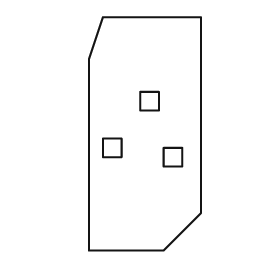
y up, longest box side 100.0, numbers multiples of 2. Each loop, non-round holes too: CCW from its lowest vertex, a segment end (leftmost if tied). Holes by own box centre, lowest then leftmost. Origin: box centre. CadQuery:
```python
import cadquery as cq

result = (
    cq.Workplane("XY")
    .moveTo(-24.0, -50.0)
    .lineTo(8.0, -50.0)
    .lineTo(24.0, -34.0)
    .lineTo(24.0, 50.0)
    .lineTo(-18.0, 50.0)
    .lineTo(-24.0, 32.0)
    .close()
    .moveTo(8.0, -14.0)
    .lineTo(16.0, -14.0)
    .lineTo(16.0, -6.0)
    .lineTo(8.0, -6.0)
    .close()
    .moveTo(-18.0, -10.0)
    .lineTo(-10.0, -10.0)
    .lineTo(-10.0, -2.0)
    .lineTo(-18.0, -2.0)
    .close()
    .moveTo(-2.0, 10.0)
    .lineTo(6.0, 10.0)
    .lineTo(6.0, 18.0)
    .lineTo(-2.0, 18.0)
    .close()
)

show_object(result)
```